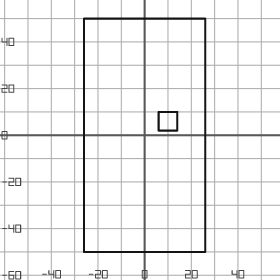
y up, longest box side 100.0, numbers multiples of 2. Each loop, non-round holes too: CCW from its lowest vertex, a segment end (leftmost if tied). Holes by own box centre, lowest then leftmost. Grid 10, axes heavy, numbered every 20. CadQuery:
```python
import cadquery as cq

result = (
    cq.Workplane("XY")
    .moveTo(-26.0, -50.0)
    .lineTo(26.0, -50.0)
    .lineTo(26.0, 50.0)
    .lineTo(-26.0, 50.0)
    .close()
    .moveTo(6.0, 2.0)
    .lineTo(14.0, 2.0)
    .lineTo(14.0, 10.0)
    .lineTo(6.0, 10.0)
    .close()
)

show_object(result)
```